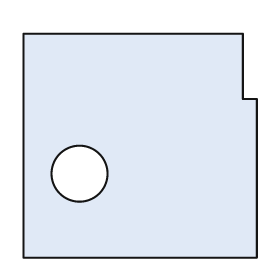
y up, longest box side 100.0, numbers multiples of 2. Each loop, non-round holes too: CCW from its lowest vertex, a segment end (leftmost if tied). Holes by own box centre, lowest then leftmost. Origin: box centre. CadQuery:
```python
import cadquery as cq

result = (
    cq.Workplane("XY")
    .moveTo(-50.0, -48.0)
    .lineTo(50.0, -48.0)
    .lineTo(50.0, 20.0)
    .lineTo(44.0, 20.0)
    .lineTo(44.0, 48.0)
    .lineTo(-50.0, 48.0)
    .close()
    .moveTo(-26.0, -12.0)
    .circle(12.0)
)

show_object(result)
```